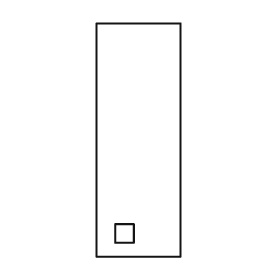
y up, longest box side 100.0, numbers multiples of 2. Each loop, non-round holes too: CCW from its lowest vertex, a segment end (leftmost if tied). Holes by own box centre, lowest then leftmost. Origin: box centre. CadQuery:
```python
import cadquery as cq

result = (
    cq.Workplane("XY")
    .moveTo(-18.0, -50.0)
    .lineTo(18.0, -50.0)
    .lineTo(18.0, 50.0)
    .lineTo(-18.0, 50.0)
    .close()
    .moveTo(-10.0, -44.0)
    .lineTo(-2.0, -44.0)
    .lineTo(-2.0, -36.0)
    .lineTo(-10.0, -36.0)
    .close()
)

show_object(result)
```